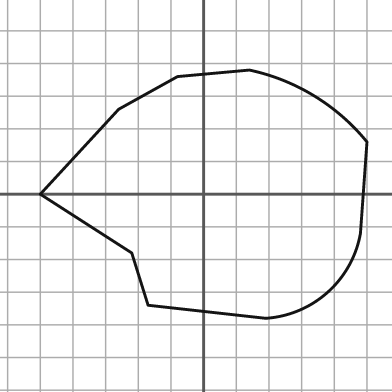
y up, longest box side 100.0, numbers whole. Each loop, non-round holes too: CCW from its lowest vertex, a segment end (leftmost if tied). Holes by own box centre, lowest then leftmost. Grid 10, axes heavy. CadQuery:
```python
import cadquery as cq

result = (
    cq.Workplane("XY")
    .moveTo(19.0, -38.0)
    .threePointArc((38.0, -30.0), (48.0, -12.0))
    .lineTo(50.0, 16.0)
    .threePointArc((34.0, 30.0), (14.0, 38.0))
    .lineTo(-8.0, 36.0)
    .lineTo(-26.0, 26.0)
    .lineTo(-50.0, 0.0)
    .lineTo(-22.0, -18.0)
    .lineTo(-17.0, -34.0)
    .close()
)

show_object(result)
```